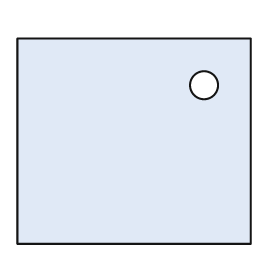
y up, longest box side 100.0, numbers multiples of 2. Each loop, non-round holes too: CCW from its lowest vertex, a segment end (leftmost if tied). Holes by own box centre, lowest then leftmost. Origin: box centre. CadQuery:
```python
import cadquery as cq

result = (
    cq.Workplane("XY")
    .moveTo(-50.0, -44.0)
    .lineTo(50.0, -44.0)
    .lineTo(50.0, 44.0)
    .lineTo(-50.0, 44.0)
    .close()
    .moveTo(30.0, 24.0)
    .circle(6.0)
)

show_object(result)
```